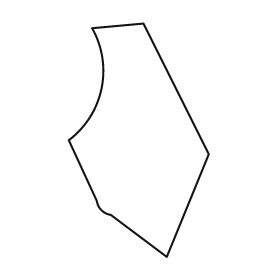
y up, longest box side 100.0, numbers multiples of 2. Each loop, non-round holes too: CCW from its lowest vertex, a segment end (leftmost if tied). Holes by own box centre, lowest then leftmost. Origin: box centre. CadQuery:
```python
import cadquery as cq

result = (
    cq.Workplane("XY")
    .moveTo(12.0, -50.0)
    .lineTo(30.0, -6.0)
    .lineTo(2.0, 50.0)
    .lineTo(-20.0, 48.0)
    .threePointArc((-16.0, 22.0), (-30.0, 0.0))
    .lineTo(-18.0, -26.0)
    .threePointArc((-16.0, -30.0), (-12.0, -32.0))
    .close()
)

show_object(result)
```